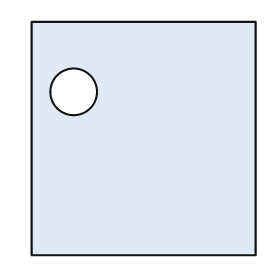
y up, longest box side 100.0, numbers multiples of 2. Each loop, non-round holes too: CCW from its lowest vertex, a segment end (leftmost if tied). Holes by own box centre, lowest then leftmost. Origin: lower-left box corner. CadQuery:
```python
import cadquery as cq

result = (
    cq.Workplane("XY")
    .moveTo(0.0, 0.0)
    .lineTo(96.0, 0.0)
    .lineTo(96.0, 100.0)
    .lineTo(0.0, 100.0)
    .close()
    .moveTo(18.0, 70.0)
    .circle(10.0)
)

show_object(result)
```